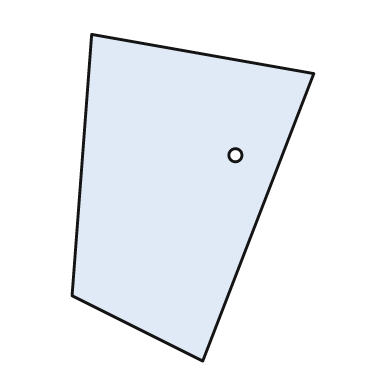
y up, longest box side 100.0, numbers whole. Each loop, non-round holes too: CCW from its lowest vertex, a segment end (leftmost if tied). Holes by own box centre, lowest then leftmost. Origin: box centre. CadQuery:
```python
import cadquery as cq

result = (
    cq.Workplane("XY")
    .moveTo(3.0, -50.0)
    .lineTo(37.0, 38.0)
    .lineTo(-31.0, 50.0)
    .lineTo(-37.0, -30.0)
    .close()
    .moveTo(13.0, 13.0)
    .circle(2.0)
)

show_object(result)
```